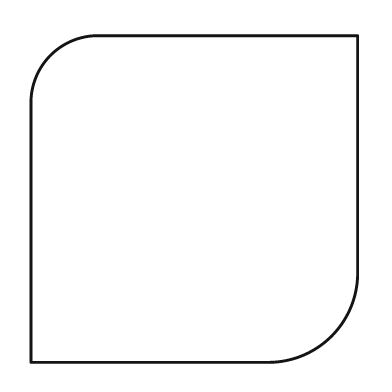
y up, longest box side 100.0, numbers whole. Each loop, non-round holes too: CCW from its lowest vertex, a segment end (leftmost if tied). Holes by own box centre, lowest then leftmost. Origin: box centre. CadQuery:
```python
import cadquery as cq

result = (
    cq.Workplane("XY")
    .moveTo(-50.0, -50.0)
    .lineTo(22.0, -50.0)
    .threePointArc((42.0, -42.0), (50.0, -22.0))
    .lineTo(50.0, 50.0)
    .lineTo(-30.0, 50.0)
    .threePointArc((-44.0, 44.0), (-50.0, 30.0))
    .close()
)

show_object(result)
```